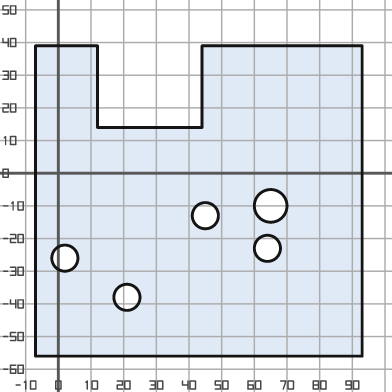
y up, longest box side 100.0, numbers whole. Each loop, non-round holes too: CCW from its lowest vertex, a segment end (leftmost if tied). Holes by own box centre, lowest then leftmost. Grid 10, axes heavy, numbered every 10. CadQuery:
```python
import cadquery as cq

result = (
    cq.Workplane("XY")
    .moveTo(-7.0, -56.0)
    .lineTo(93.0, -56.0)
    .lineTo(93.0, 39.0)
    .lineTo(44.0, 39.0)
    .lineTo(44.0, 14.0)
    .lineTo(12.0, 14.0)
    .lineTo(12.0, 39.0)
    .lineTo(-7.0, 39.0)
    .close()
    .moveTo(21.0, -38.0)
    .circle(4.0)
    .moveTo(2.0, -26.0)
    .circle(4.0)
    .moveTo(64.0, -23.0)
    .circle(4.0)
    .moveTo(45.0, -13.0)
    .circle(4.0)
    .moveTo(65.0, -10.0)
    .circle(5.0)
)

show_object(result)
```